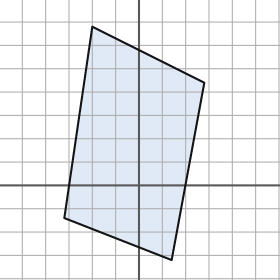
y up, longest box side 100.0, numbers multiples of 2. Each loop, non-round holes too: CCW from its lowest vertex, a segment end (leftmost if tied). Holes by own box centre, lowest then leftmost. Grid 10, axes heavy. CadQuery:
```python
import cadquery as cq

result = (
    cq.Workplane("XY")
    .moveTo(14.0, -32.0)
    .lineTo(28.0, 44.0)
    .lineTo(-20.0, 68.0)
    .lineTo(-32.0, -14.0)
    .close()
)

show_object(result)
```